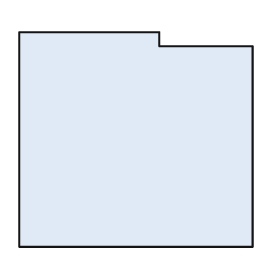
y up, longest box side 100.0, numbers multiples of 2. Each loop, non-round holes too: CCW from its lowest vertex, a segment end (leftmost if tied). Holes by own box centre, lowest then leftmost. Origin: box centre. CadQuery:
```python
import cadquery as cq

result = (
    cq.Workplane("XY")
    .moveTo(-50.0, -46.0)
    .lineTo(50.0, -46.0)
    .lineTo(50.0, 40.0)
    .lineTo(10.0, 40.0)
    .lineTo(10.0, 46.0)
    .lineTo(-50.0, 46.0)
    .close()
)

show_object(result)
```